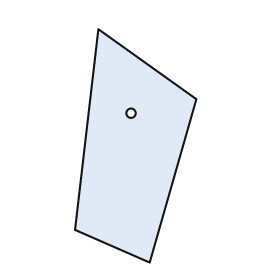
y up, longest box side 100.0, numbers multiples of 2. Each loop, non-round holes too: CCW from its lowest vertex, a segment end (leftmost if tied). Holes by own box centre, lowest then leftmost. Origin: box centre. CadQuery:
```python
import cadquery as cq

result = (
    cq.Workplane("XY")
    .moveTo(6.0, -50.0)
    .lineTo(26.0, 20.0)
    .lineTo(-16.0, 50.0)
    .lineTo(-26.0, -36.0)
    .close()
    .moveTo(-2.0, 14.0)
    .circle(2.0)
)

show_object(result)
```